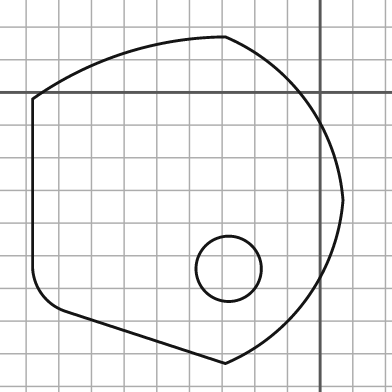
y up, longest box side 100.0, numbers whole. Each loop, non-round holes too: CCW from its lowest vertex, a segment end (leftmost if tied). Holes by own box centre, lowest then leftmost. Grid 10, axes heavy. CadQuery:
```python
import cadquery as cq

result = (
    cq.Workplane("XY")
    .moveTo(-29.0, -83.0)
    .threePointArc((-4.0, -63.0), (7.0, -33.0))
    .threePointArc((-4.0, -3.0), (-29.0, 17.0))
    .threePointArc((-60.0, 12.0), (-88.0, -2.0))
    .lineTo(-88.0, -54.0)
    .threePointArc((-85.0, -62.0), (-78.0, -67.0))
    .close()
    .moveTo(-28.0, -54.0)
    .circle(10.0)
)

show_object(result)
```